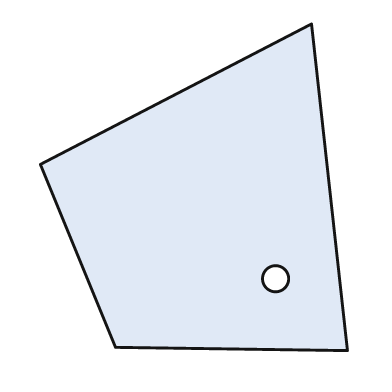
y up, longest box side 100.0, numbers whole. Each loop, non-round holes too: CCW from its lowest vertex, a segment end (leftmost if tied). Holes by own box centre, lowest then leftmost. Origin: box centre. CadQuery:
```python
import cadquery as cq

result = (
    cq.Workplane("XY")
    .moveTo(47.0, -50.0)
    .lineTo(36.0, 50.0)
    .lineTo(-47.0, 7.0)
    .lineTo(-24.0, -49.0)
    .close()
    .moveTo(25.0, -28.0)
    .circle(4.0)
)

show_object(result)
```